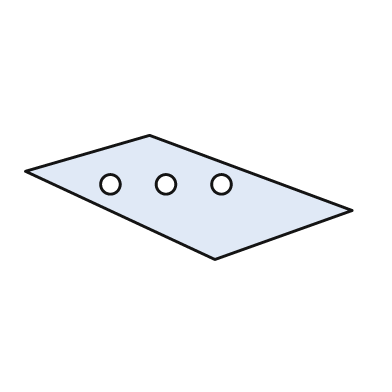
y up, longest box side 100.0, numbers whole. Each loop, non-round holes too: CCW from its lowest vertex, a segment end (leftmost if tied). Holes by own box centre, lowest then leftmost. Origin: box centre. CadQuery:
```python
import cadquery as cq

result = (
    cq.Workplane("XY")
    .moveTo(8.0, -19.0)
    .lineTo(50.0, -4.0)
    .lineTo(-12.0, 19.0)
    .lineTo(-50.0, 8.0)
    .close()
    .moveTo(-24.0, 4.0)
    .circle(3.0)
    .moveTo(-7.0, 4.0)
    .circle(3.0)
    .moveTo(10.0, 4.0)
    .circle(3.0)
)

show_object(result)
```